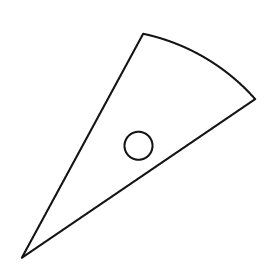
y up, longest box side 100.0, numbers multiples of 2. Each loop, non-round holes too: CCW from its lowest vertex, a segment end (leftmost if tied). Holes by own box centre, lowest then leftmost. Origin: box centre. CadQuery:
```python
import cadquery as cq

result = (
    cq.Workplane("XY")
    .moveTo(-50.0, -48.0)
    .lineTo(50.0, 20.0)
    .threePointArc((28.0, 38.0), (2.0, 48.0))
    .close()
    .moveTo(0.0, 0.0)
    .circle(6.0)
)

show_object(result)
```